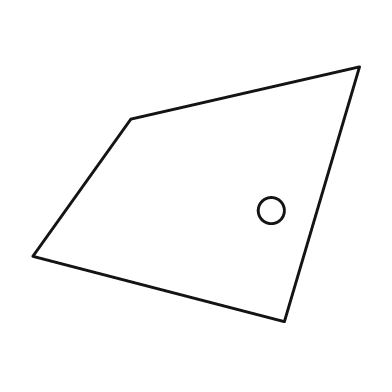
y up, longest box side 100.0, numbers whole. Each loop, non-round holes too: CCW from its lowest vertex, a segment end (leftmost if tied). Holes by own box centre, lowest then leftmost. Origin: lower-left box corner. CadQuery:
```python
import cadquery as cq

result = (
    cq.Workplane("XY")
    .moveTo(77.0, 0.0)
    .lineTo(100.0, 78.0)
    .lineTo(30.0, 62.0)
    .lineTo(0.0, 20.0)
    .close()
    .moveTo(73.0, 34.0)
    .circle(4.0)
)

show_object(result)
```